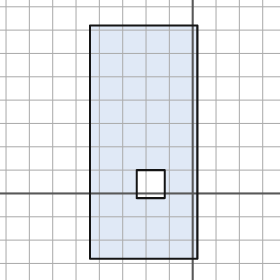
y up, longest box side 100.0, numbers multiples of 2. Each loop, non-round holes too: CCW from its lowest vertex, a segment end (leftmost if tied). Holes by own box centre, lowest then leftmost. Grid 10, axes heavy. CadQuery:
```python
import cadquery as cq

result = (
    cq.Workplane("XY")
    .moveTo(-44.0, -28.0)
    .lineTo(2.0, -28.0)
    .lineTo(2.0, 72.0)
    .lineTo(-44.0, 72.0)
    .close()
    .moveTo(-24.0, -2.0)
    .lineTo(-12.0, -2.0)
    .lineTo(-12.0, 10.0)
    .lineTo(-24.0, 10.0)
    .close()
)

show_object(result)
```